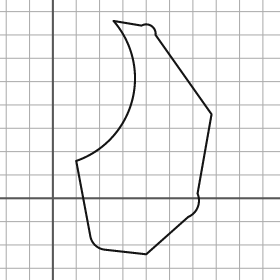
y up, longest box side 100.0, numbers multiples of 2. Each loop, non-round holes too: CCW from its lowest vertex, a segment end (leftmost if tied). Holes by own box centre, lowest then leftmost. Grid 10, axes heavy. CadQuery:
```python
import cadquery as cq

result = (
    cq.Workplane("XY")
    .moveTo(40.0, -24.0)
    .lineTo(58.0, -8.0)
    .threePointArc((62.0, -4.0), (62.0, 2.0))
    .lineTo(68.0, 36.0)
    .lineTo(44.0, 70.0)
    .threePointArc((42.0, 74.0), (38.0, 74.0))
    .lineTo(26.0, 76.0)
    .threePointArc((34.0, 42.0), (10.0, 16.0))
    .lineTo(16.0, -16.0)
    .threePointArc((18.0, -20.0), (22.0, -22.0))
    .close()
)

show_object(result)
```